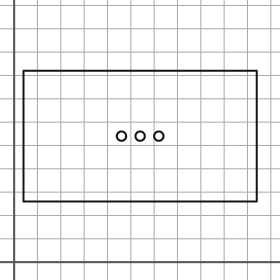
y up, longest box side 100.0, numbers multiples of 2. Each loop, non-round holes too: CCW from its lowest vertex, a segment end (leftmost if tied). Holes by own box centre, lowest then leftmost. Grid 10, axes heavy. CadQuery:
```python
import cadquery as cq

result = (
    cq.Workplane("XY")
    .moveTo(4.0, 26.0)
    .lineTo(104.0, 26.0)
    .lineTo(104.0, 82.0)
    .lineTo(4.0, 82.0)
    .close()
    .moveTo(46.0, 54.0)
    .circle(2.0)
    .moveTo(54.0, 54.0)
    .circle(2.0)
    .moveTo(62.0, 54.0)
    .circle(2.0)
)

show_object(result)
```